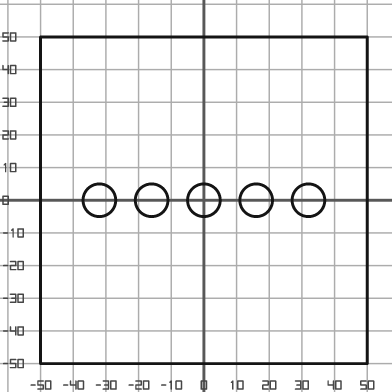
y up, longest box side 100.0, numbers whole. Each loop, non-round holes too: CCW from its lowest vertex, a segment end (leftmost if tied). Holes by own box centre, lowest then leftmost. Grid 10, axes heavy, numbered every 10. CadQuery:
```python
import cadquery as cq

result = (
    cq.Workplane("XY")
    .moveTo(-50.0, -50.0)
    .lineTo(50.0, -50.0)
    .lineTo(50.0, 50.0)
    .lineTo(-50.0, 50.0)
    .close()
    .moveTo(-32.0, 0.0)
    .circle(5.0)
    .moveTo(-16.0, 0.0)
    .circle(5.0)
    .moveTo(0.0, 0.0)
    .circle(5.0)
    .moveTo(16.0, 0.0)
    .circle(5.0)
    .moveTo(32.0, 0.0)
    .circle(5.0)
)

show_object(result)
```